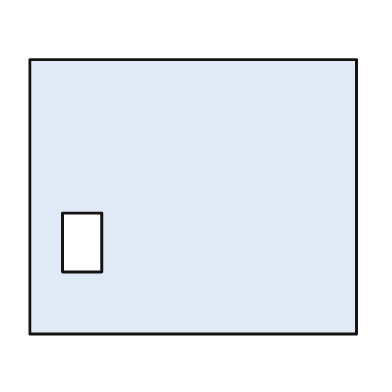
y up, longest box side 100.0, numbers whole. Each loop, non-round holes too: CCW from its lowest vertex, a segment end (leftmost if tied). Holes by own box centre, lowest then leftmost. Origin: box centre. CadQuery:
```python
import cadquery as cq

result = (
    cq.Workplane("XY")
    .moveTo(-50.0, -42.0)
    .lineTo(50.0, -42.0)
    .lineTo(50.0, 42.0)
    .lineTo(-50.0, 42.0)
    .close()
    .moveTo(-40.0, -23.0)
    .lineTo(-28.0, -23.0)
    .lineTo(-28.0, -5.0)
    .lineTo(-40.0, -5.0)
    .close()
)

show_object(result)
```